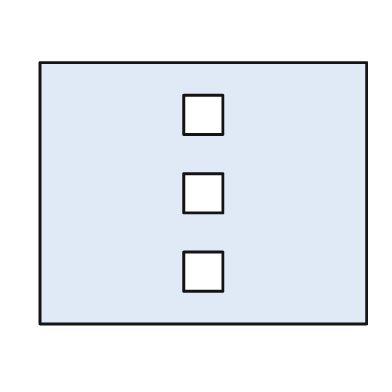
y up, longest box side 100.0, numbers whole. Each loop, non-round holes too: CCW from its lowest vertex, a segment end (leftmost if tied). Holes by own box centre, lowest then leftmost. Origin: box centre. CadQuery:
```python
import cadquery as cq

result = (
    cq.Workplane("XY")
    .moveTo(-50.0, -40.0)
    .lineTo(50.0, -40.0)
    .lineTo(50.0, 40.0)
    .lineTo(-50.0, 40.0)
    .close()
    .moveTo(-6.0, -30.0)
    .lineTo(6.0, -30.0)
    .lineTo(6.0, -18.0)
    .lineTo(-6.0, -18.0)
    .close()
    .moveTo(-6.0, -6.0)
    .lineTo(6.0, -6.0)
    .lineTo(6.0, 6.0)
    .lineTo(-6.0, 6.0)
    .close()
    .moveTo(-6.0, 18.0)
    .lineTo(6.0, 18.0)
    .lineTo(6.0, 30.0)
    .lineTo(-6.0, 30.0)
    .close()
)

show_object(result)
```